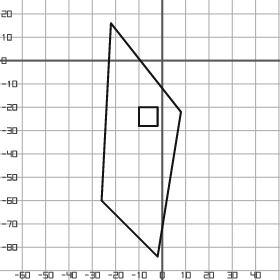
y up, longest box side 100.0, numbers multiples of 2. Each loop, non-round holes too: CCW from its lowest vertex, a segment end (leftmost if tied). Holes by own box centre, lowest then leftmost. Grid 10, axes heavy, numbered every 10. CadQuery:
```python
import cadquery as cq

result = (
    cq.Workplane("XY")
    .moveTo(-2.0, -84.0)
    .lineTo(8.0, -22.0)
    .lineTo(-22.0, 16.0)
    .lineTo(-26.0, -60.0)
    .close()
    .moveTo(-10.0, -28.0)
    .lineTo(-2.0, -28.0)
    .lineTo(-2.0, -20.0)
    .lineTo(-10.0, -20.0)
    .close()
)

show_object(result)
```